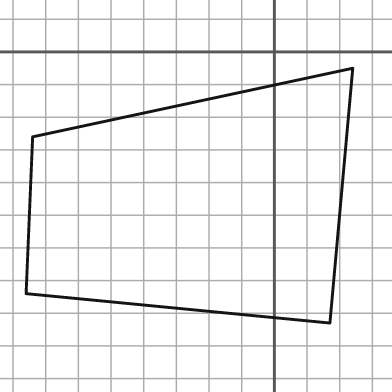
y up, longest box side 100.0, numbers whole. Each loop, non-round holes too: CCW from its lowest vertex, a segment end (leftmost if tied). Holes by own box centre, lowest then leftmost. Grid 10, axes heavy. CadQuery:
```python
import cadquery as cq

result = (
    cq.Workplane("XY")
    .moveTo(17.0, -83.0)
    .lineTo(24.0, -5.0)
    .lineTo(-74.0, -26.0)
    .lineTo(-76.0, -74.0)
    .close()
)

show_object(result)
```